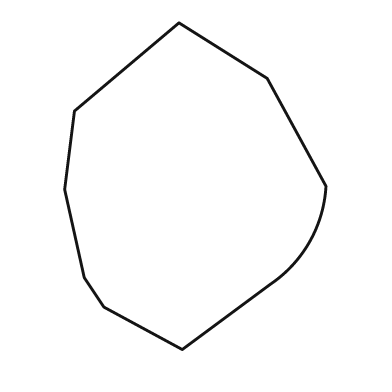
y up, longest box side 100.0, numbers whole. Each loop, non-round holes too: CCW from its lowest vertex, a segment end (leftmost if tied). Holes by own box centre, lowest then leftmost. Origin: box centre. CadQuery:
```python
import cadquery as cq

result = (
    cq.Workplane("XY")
    .moveTo(-4.0, -50.0)
    .lineTo(23.0, -30.0)
    .threePointArc((35.0, -17.0), (40.0, 0.0))
    .lineTo(22.0, 33.0)
    .lineTo(-5.0, 50.0)
    .lineTo(-37.0, 23.0)
    .lineTo(-40.0, -1.0)
    .lineTo(-34.0, -28.0)
    .lineTo(-28.0, -37.0)
    .close()
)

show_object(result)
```